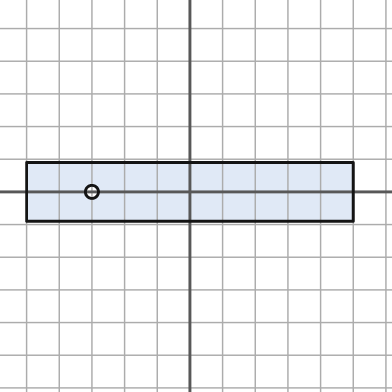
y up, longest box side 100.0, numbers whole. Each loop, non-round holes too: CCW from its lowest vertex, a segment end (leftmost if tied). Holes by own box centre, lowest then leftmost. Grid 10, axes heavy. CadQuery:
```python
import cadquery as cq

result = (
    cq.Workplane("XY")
    .moveTo(-50.0, -9.0)
    .lineTo(50.0, -9.0)
    .lineTo(50.0, 9.0)
    .lineTo(-50.0, 9.0)
    .close()
    .moveTo(-30.0, 0.0)
    .circle(2.0)
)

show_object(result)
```